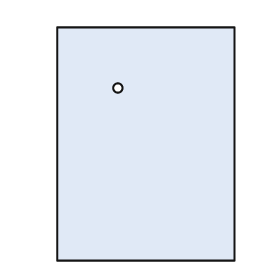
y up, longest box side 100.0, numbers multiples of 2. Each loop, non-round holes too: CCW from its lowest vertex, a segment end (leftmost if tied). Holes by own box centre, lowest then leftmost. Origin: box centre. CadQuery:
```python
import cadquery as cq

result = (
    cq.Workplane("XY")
    .moveTo(-38.0, -50.0)
    .lineTo(38.0, -50.0)
    .lineTo(38.0, 50.0)
    .lineTo(-38.0, 50.0)
    .close()
    .moveTo(-12.0, 24.0)
    .circle(2.0)
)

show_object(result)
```